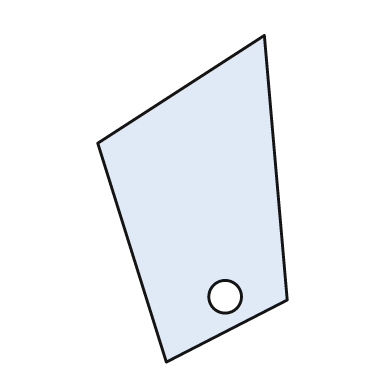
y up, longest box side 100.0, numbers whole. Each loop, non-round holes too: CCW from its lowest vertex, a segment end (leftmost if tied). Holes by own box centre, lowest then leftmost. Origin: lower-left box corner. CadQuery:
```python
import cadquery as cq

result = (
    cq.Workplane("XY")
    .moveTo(21.0, 0.0)
    .lineTo(58.0, 19.0)
    .lineTo(51.0, 100.0)
    .lineTo(0.0, 67.0)
    .close()
    .moveTo(39.0, 20.0)
    .circle(5.0)
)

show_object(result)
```